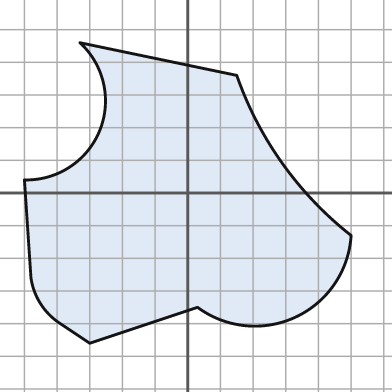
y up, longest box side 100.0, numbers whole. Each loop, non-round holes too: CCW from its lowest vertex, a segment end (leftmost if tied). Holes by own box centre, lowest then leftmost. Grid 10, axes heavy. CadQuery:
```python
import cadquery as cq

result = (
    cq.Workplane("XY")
    .moveTo(-30.0, -46.0)
    .lineTo(3.0, -35.0)
    .threePointArc((33.0, -38.0), (50.0, -13.0))
    .threePointArc((29.0, 9.0), (15.0, 36.0))
    .lineTo(-33.0, 46.0)
    .threePointArc((-27.0, 19.0), (-50.0, 4.0))
    .lineTo(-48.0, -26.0)
    .threePointArc((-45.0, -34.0), (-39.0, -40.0))
    .close()
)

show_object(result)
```